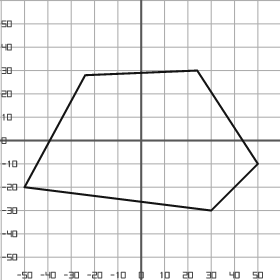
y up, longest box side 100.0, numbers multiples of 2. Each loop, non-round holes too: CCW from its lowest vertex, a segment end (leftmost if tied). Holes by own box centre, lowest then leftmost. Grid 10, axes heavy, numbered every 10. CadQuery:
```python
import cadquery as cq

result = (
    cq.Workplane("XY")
    .moveTo(30.0, -30.0)
    .lineTo(50.0, -10.0)
    .lineTo(24.0, 30.0)
    .lineTo(-24.0, 28.0)
    .lineTo(-50.0, -20.0)
    .close()
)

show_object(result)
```